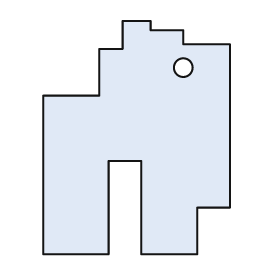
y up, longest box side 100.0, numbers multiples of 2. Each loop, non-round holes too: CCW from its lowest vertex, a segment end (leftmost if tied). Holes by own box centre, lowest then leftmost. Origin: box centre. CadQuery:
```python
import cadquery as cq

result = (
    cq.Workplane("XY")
    .moveTo(-40.0, -50.0)
    .lineTo(-12.0, -50.0)
    .lineTo(-12.0, -10.0)
    .lineTo(2.0, -10.0)
    .lineTo(2.0, -50.0)
    .lineTo(26.0, -50.0)
    .lineTo(26.0, -30.0)
    .lineTo(40.0, -30.0)
    .lineTo(40.0, 40.0)
    .lineTo(20.0, 40.0)
    .lineTo(20.0, 46.0)
    .lineTo(6.0, 46.0)
    .lineTo(6.0, 50.0)
    .lineTo(-6.0, 50.0)
    .lineTo(-6.0, 38.0)
    .lineTo(-16.0, 38.0)
    .lineTo(-16.0, 18.0)
    .lineTo(-40.0, 18.0)
    .close()
    .moveTo(20.0, 30.0)
    .circle(4.0)
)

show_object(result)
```